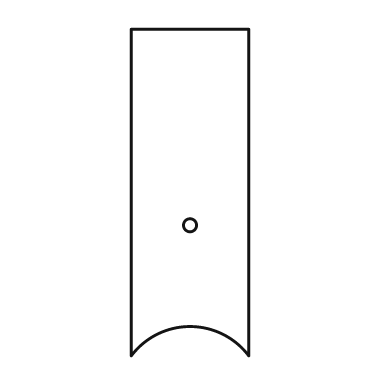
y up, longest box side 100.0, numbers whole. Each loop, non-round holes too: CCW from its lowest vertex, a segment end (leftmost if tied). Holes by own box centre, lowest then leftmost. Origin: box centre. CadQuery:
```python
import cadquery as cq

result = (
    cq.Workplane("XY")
    .moveTo(-18.0, -50.0)
    .threePointArc((0.0, -41.0), (18.0, -50.0))
    .lineTo(18.0, 50.0)
    .lineTo(-18.0, 50.0)
    .close()
    .moveTo(0.0, -10.0)
    .circle(2.0)
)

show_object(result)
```